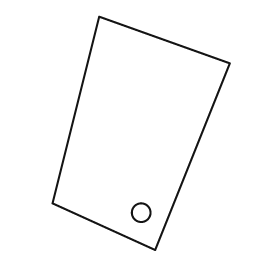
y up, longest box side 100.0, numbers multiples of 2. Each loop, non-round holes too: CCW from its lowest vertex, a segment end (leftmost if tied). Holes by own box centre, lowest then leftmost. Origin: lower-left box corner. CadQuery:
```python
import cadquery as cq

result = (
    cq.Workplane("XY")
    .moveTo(44.0, 0.0)
    .lineTo(76.0, 80.0)
    .lineTo(20.0, 100.0)
    .lineTo(0.0, 20.0)
    .close()
    .moveTo(38.0, 16.0)
    .circle(4.0)
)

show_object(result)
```